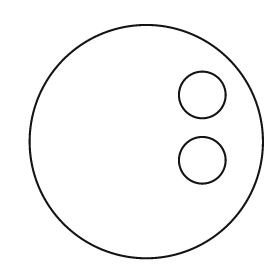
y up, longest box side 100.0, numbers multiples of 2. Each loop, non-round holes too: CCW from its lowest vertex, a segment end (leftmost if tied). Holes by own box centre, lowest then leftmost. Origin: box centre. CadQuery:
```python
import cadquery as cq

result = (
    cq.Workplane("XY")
    .moveTo(0.0, 0.0)
    .circle(50.0)
    .moveTo(24.0, -8.0)
    .circle(10.0)
    .moveTo(24.0, 20.0)
    .circle(10.0)
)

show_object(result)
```